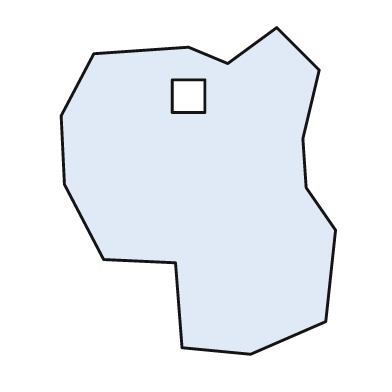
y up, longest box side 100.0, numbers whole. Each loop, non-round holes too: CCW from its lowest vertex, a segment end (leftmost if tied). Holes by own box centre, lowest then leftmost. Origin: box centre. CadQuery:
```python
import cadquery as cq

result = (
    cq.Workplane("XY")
    .moveTo(16.0, -50.0)
    .lineTo(39.0, -40.0)
    .lineTo(42.0, -12.0)
    .lineTo(33.0, 1.0)
    .lineTo(32.0, 16.0)
    .lineTo(37.0, 37.0)
    .lineTo(24.0, 50.0)
    .lineTo(9.0, 39.0)
    .lineTo(-3.0, 44.0)
    .lineTo(-32.0, 42.0)
    .lineTo(-42.0, 23.0)
    .lineTo(-41.0, 2.0)
    .lineTo(-29.0, -21.0)
    .lineTo(-7.0, -22.0)
    .lineTo(-5.0, -48.0)
    .close()
    .moveTo(-8.0, 24.0)
    .lineTo(2.0, 24.0)
    .lineTo(2.0, 34.0)
    .lineTo(-8.0, 34.0)
    .close()
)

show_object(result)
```